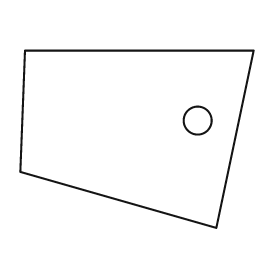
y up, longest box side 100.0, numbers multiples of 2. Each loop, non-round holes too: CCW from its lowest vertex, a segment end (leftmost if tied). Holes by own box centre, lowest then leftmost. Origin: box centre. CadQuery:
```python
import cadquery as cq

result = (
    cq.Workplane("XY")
    .moveTo(34.0, -38.0)
    .lineTo(50.0, 38.0)
    .lineTo(-48.0, 38.0)
    .lineTo(-50.0, -14.0)
    .close()
    .moveTo(26.0, 8.0)
    .circle(6.0)
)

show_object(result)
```